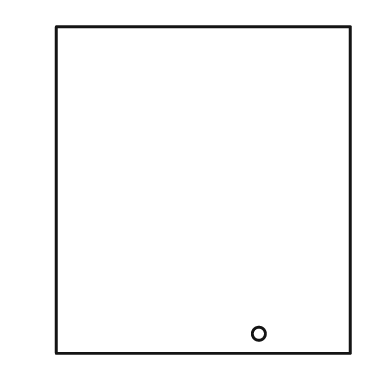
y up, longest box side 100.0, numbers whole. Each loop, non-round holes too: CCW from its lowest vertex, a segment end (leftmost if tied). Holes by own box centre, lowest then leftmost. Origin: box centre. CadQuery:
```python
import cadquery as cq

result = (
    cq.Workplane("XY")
    .moveTo(-45.0, -50.0)
    .lineTo(45.0, -50.0)
    .lineTo(45.0, 50.0)
    .lineTo(-45.0, 50.0)
    .close()
    .moveTo(17.0, -44.0)
    .circle(2.0)
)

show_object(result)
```